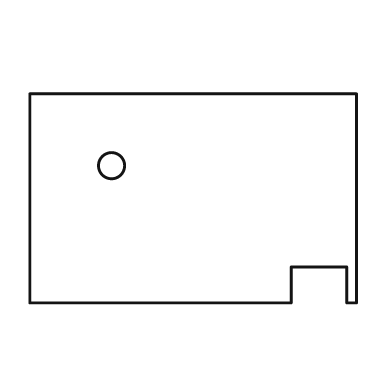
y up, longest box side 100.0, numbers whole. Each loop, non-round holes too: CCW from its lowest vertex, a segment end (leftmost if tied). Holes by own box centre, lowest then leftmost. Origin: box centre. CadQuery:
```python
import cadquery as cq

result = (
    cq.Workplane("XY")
    .moveTo(-50.0, -32.0)
    .lineTo(30.0, -32.0)
    .lineTo(30.0, -21.0)
    .lineTo(47.0, -21.0)
    .lineTo(47.0, -32.0)
    .lineTo(50.0, -32.0)
    .lineTo(50.0, 32.0)
    .lineTo(-50.0, 32.0)
    .close()
    .moveTo(-25.0, 10.0)
    .circle(4.0)
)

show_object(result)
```